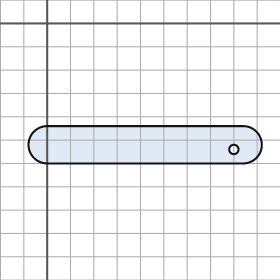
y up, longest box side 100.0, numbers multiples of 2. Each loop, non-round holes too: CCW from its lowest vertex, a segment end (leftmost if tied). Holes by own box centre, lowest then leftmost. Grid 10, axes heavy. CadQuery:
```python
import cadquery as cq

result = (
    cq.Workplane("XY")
    .moveTo(0.0, -60.0)
    .lineTo(84.0, -60.0)
    .threePointArc((92.0, -52.0), (84.0, -44.0))
    .lineTo(0.0, -44.0)
    .threePointArc((-8.0, -52.0), (0.0, -60.0))
    .close()
    .moveTo(80.0, -54.0)
    .circle(2.0)
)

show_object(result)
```